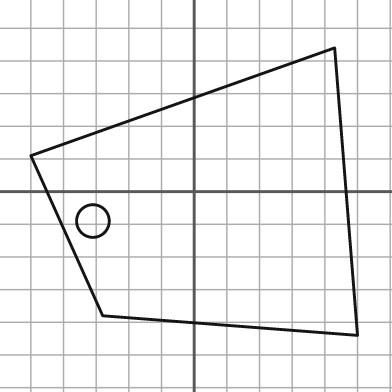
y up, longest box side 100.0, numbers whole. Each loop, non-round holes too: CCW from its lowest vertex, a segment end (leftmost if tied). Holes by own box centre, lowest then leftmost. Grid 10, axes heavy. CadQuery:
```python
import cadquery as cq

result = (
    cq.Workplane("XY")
    .moveTo(50.0, -44.0)
    .lineTo(43.0, 44.0)
    .lineTo(-50.0, 11.0)
    .lineTo(-28.0, -38.0)
    .close()
    .moveTo(-31.0, -9.0)
    .circle(5.0)
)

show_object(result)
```